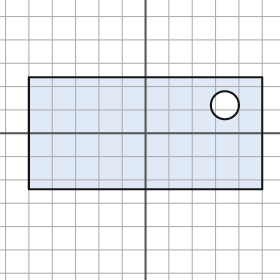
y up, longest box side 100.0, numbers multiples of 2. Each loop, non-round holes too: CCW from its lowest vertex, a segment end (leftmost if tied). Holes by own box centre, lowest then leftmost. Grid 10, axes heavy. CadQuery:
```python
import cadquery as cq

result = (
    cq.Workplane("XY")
    .moveTo(-50.0, -24.0)
    .lineTo(50.0, -24.0)
    .lineTo(50.0, 24.0)
    .lineTo(-50.0, 24.0)
    .close()
    .moveTo(34.0, 12.0)
    .circle(6.0)
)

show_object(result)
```